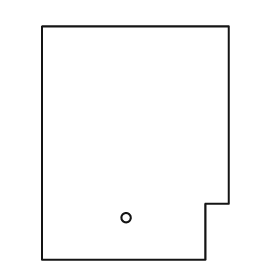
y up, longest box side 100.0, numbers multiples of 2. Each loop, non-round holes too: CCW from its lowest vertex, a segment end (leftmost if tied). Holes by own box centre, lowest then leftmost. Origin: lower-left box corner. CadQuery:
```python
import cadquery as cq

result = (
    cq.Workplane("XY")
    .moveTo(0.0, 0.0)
    .lineTo(70.0, 0.0)
    .lineTo(70.0, 24.0)
    .lineTo(80.0, 24.0)
    .lineTo(80.0, 100.0)
    .lineTo(0.0, 100.0)
    .close()
    .moveTo(36.0, 18.0)
    .circle(2.0)
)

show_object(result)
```